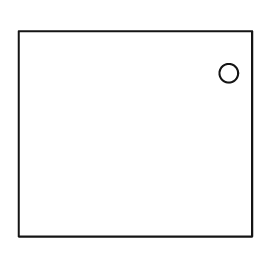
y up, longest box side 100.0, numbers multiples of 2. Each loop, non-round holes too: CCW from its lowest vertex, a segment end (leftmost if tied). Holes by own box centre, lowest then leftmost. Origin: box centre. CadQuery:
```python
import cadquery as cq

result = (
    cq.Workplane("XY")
    .moveTo(-50.0, -44.0)
    .lineTo(50.0, -44.0)
    .lineTo(50.0, 44.0)
    .lineTo(-50.0, 44.0)
    .close()
    .moveTo(40.0, 26.0)
    .circle(4.0)
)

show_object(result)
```